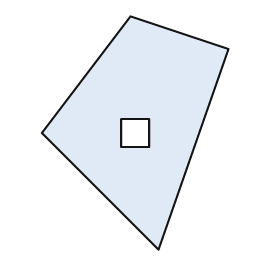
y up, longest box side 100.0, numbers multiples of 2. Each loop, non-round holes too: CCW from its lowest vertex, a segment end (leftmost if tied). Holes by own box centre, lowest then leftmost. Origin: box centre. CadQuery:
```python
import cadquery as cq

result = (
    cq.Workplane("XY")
    .moveTo(10.0, -50.0)
    .lineTo(40.0, 36.0)
    .lineTo(-2.0, 50.0)
    .lineTo(-40.0, 0.0)
    .close()
    .moveTo(-6.0, -6.0)
    .lineTo(6.0, -6.0)
    .lineTo(6.0, 6.0)
    .lineTo(-6.0, 6.0)
    .close()
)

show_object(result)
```